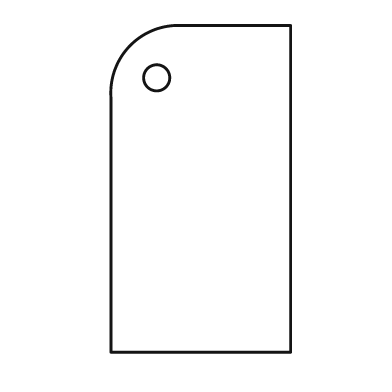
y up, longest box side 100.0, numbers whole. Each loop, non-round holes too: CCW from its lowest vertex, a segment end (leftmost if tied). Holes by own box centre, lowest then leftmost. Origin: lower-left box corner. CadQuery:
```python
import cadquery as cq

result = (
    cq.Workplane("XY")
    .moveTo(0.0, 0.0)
    .lineTo(55.0, 0.0)
    .lineTo(55.0, 100.0)
    .lineTo(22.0, 100.0)
    .threePointArc((6.0, 94.0), (0.0, 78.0))
    .close()
    .moveTo(14.0, 84.0)
    .circle(4.0)
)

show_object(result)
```